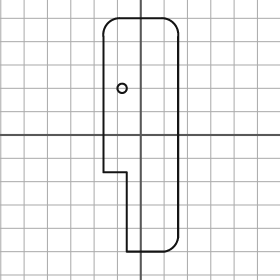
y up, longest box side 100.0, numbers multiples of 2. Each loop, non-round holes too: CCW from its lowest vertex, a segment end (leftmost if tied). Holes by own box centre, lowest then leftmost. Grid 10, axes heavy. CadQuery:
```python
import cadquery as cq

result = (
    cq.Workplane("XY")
    .moveTo(-6.0, -50.0)
    .lineTo(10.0, -50.0)
    .threePointArc((14.0, -48.0), (16.0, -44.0))
    .lineTo(16.0, 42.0)
    .threePointArc((14.0, 48.0), (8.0, 50.0))
    .lineTo(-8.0, 50.0)
    .threePointArc((-14.0, 48.0), (-16.0, 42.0))
    .lineTo(-16.0, -16.0)
    .lineTo(-6.0, -16.0)
    .close()
    .moveTo(-8.0, 20.0)
    .circle(2.0)
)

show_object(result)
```